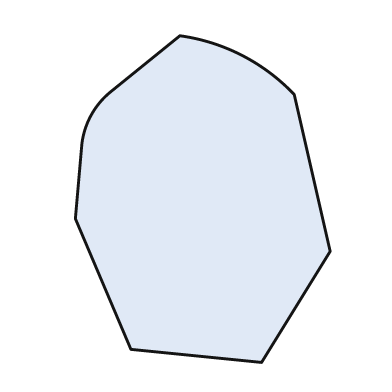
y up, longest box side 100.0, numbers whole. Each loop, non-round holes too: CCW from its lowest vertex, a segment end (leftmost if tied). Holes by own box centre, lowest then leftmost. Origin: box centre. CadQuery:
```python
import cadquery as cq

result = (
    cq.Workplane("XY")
    .moveTo(18.0, -50.0)
    .lineTo(39.0, -16.0)
    .lineTo(28.0, 32.0)
    .threePointArc((12.0, 44.0), (-7.0, 50.0))
    .lineTo(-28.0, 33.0)
    .threePointArc((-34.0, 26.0), (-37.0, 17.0))
    .lineTo(-39.0, -6.0)
    .lineTo(-22.0, -46.0)
    .close()
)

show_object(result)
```